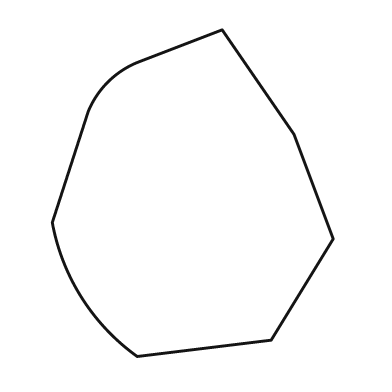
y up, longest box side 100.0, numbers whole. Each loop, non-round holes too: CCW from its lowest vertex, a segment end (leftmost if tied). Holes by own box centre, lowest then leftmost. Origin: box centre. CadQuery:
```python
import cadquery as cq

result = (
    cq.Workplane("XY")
    .moveTo(-17.0, -50.0)
    .lineTo(24.0, -45.0)
    .lineTo(43.0, -14.0)
    .lineTo(31.0, 18.0)
    .lineTo(9.0, 50.0)
    .lineTo(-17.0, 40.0)
    .threePointArc((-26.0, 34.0), (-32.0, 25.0))
    .lineTo(-43.0, -9.0)
    .threePointArc((-34.0, -32.0), (-17.0, -50.0))
    .close()
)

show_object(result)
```